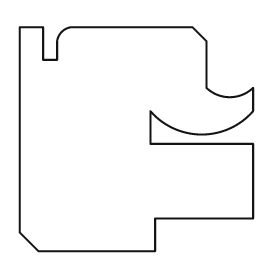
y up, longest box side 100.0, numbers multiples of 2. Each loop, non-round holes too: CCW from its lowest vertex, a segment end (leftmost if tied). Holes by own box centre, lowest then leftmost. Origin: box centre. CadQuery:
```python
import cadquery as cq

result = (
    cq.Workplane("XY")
    .moveTo(-42.0, -48.0)
    .lineTo(8.0, -48.0)
    .lineTo(8.0, -34.0)
    .lineTo(50.0, -34.0)
    .lineTo(50.0, -2.0)
    .lineTo(6.0, -2.0)
    .lineTo(6.0, 12.0)
    .threePointArc((28.0, 2.0), (50.0, 12.0))
    .lineTo(50.0, 22.0)
    .threePointArc((40.0, 18.0), (30.0, 22.0))
    .lineTo(30.0, 42.0)
    .lineTo(24.0, 48.0)
    .lineTo(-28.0, 48.0)
    .threePointArc((-32.0, 46.0), (-34.0, 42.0))
    .lineTo(-34.0, 34.0)
    .lineTo(-40.0, 34.0)
    .lineTo(-40.0, 48.0)
    .lineTo(-50.0, 48.0)
    .lineTo(-50.0, -40.0)
    .close()
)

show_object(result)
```